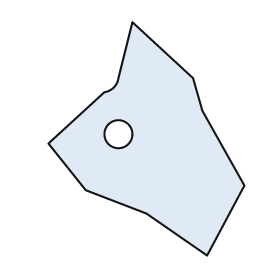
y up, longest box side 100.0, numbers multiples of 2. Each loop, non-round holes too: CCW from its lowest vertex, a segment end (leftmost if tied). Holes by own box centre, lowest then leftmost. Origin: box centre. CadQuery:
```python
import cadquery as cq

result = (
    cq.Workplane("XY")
    .moveTo(26.0, -50.0)
    .lineTo(42.0, -20.0)
    .lineTo(24.0, 12.0)
    .lineTo(20.0, 26.0)
    .lineTo(-6.0, 50.0)
    .lineTo(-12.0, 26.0)
    .threePointArc((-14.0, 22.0), (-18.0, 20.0))
    .lineTo(-42.0, -2.0)
    .lineTo(-26.0, -22.0)
    .lineTo(0.0, -32.0)
    .close()
    .moveTo(-12.0, 2.0)
    .circle(6.0)
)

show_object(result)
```